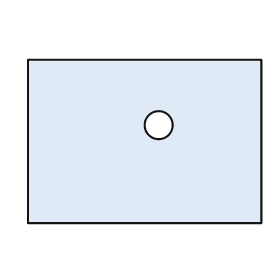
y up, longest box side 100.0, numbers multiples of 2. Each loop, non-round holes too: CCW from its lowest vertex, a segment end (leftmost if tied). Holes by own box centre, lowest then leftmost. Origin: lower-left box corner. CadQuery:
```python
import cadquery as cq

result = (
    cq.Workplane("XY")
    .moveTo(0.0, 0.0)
    .lineTo(100.0, 0.0)
    .lineTo(100.0, 70.0)
    .lineTo(0.0, 70.0)
    .close()
    .moveTo(56.0, 42.0)
    .circle(6.0)
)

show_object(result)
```